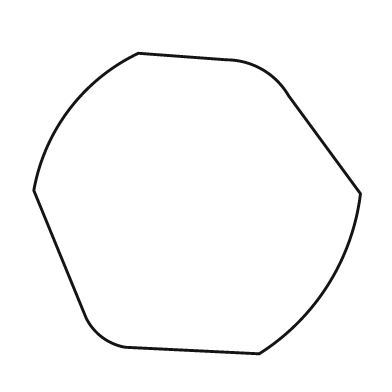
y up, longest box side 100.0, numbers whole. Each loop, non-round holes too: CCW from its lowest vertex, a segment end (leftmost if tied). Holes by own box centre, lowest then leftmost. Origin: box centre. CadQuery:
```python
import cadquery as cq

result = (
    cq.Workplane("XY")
    .moveTo(19.0, -46.0)
    .threePointArc((40.0, -25.0), (50.0, 3.0))
    .lineTo(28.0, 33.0)
    .threePointArc((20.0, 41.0), (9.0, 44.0))
    .lineTo(-18.0, 46.0)
    .threePointArc((-39.0, 29.0), (-50.0, 4.0))
    .lineTo(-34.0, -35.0)
    .threePointArc((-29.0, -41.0), (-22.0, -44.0))
    .close()
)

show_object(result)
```